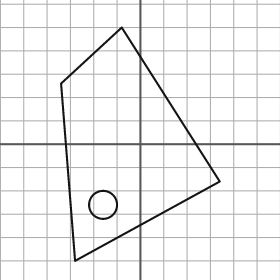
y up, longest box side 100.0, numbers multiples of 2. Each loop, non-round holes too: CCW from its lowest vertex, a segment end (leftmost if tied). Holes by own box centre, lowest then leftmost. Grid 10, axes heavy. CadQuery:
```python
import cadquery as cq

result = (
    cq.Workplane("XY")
    .moveTo(-28.0, -50.0)
    .lineTo(34.0, -16.0)
    .lineTo(-8.0, 50.0)
    .lineTo(-34.0, 26.0)
    .close()
    .moveTo(-16.0, -26.0)
    .circle(6.0)
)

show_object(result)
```